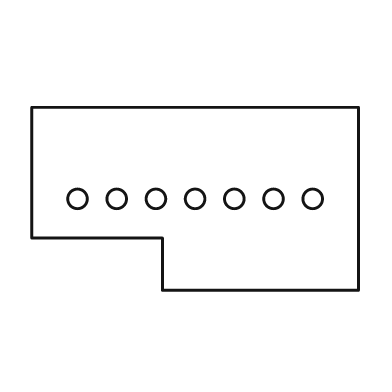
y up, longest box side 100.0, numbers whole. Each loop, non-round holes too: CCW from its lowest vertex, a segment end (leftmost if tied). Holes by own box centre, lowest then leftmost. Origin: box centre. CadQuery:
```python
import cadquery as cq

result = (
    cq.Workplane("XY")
    .moveTo(-10.0, -28.0)
    .lineTo(50.0, -28.0)
    .lineTo(50.0, 28.0)
    .lineTo(-50.0, 28.0)
    .lineTo(-50.0, -12.0)
    .lineTo(-10.0, -12.0)
    .close()
    .moveTo(-36.0, 0.0)
    .circle(3.0)
    .moveTo(-24.0, 0.0)
    .circle(3.0)
    .moveTo(-12.0, 0.0)
    .circle(3.0)
    .moveTo(0.0, 0.0)
    .circle(3.0)
    .moveTo(12.0, 0.0)
    .circle(3.0)
    .moveTo(24.0, 0.0)
    .circle(3.0)
    .moveTo(36.0, 0.0)
    .circle(3.0)
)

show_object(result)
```